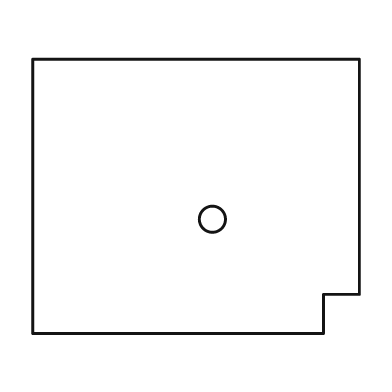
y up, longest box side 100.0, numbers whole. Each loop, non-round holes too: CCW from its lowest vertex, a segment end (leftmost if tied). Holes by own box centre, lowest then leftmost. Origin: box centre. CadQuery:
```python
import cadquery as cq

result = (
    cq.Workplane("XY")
    .moveTo(-50.0, -42.0)
    .lineTo(39.0, -42.0)
    .lineTo(39.0, -30.0)
    .lineTo(50.0, -30.0)
    .lineTo(50.0, 42.0)
    .lineTo(-50.0, 42.0)
    .close()
    .moveTo(5.0, -7.0)
    .circle(4.0)
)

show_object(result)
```